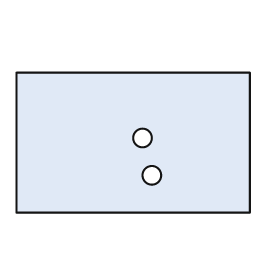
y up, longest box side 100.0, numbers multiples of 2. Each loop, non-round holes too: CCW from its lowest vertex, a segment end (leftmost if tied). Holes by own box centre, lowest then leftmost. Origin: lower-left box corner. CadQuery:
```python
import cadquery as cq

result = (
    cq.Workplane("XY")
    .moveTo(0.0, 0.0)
    .lineTo(100.0, 0.0)
    .lineTo(100.0, 60.0)
    .lineTo(0.0, 60.0)
    .close()
    .moveTo(58.0, 16.0)
    .circle(4.0)
    .moveTo(54.0, 32.0)
    .circle(4.0)
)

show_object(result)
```